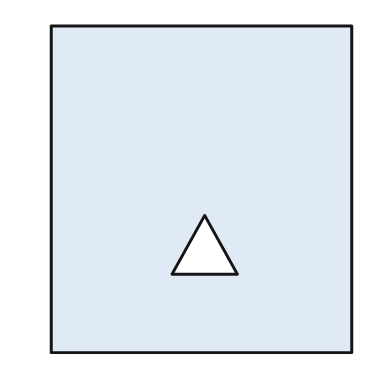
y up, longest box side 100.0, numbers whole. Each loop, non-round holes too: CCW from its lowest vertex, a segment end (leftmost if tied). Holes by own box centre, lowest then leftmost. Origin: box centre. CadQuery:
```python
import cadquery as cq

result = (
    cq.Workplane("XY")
    .moveTo(-46.0, -50.0)
    .lineTo(46.0, -50.0)
    .lineTo(46.0, 50.0)
    .lineTo(-46.0, 50.0)
    .close()
    .moveTo(-9.0, -26.0)
    .lineTo(11.0, -26.0)
    .lineTo(1.0, -8.0)
    .close()
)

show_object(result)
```